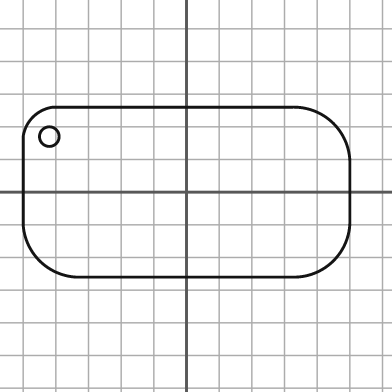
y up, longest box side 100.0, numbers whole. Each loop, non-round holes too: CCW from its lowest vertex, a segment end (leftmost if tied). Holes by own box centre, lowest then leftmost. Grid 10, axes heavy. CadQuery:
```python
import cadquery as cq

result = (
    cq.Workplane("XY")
    .moveTo(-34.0, -26.0)
    .lineTo(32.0, -26.0)
    .threePointArc((45.0, -21.0), (50.0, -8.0))
    .lineTo(50.0, 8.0)
    .threePointArc((45.0, 21.0), (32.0, 26.0))
    .lineTo(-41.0, 26.0)
    .threePointArc((-47.0, 23.0), (-50.0, 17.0))
    .lineTo(-50.0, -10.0)
    .threePointArc((-45.0, -21.0), (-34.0, -26.0))
    .close()
    .moveTo(-42.0, 17.0)
    .circle(3.0)
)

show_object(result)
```